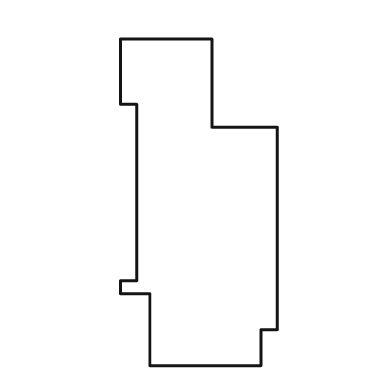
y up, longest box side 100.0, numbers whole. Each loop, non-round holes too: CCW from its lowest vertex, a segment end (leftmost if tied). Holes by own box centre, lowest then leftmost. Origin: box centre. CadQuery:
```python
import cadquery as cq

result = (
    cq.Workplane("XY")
    .moveTo(-15.0, -50.0)
    .lineTo(19.0, -50.0)
    .lineTo(19.0, -39.0)
    .lineTo(24.0, -39.0)
    .lineTo(24.0, 23.0)
    .lineTo(4.0, 23.0)
    .lineTo(4.0, 50.0)
    .lineTo(-24.0, 50.0)
    .lineTo(-24.0, 30.0)
    .lineTo(-19.0, 30.0)
    .lineTo(-19.0, -24.0)
    .lineTo(-24.0, -24.0)
    .lineTo(-24.0, -28.0)
    .lineTo(-15.0, -28.0)
    .close()
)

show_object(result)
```